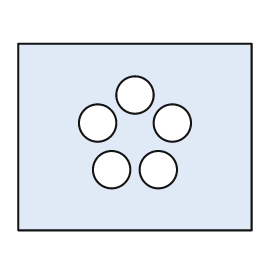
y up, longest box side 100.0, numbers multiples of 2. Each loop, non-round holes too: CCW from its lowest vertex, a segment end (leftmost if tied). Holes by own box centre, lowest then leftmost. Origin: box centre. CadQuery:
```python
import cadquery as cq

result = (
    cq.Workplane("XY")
    .moveTo(-50.0, -40.0)
    .lineTo(50.0, -40.0)
    .lineTo(50.0, 40.0)
    .lineTo(-50.0, 40.0)
    .close()
    .moveTo(-10.0, -14.0)
    .circle(8.0)
    .moveTo(10.0, -14.0)
    .circle(8.0)
    .moveTo(-16.0, 6.0)
    .circle(8.0)
    .moveTo(16.0, 6.0)
    .circle(8.0)
    .moveTo(0.0, 18.0)
    .circle(8.0)
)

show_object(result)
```